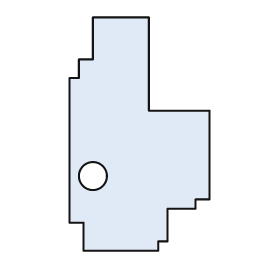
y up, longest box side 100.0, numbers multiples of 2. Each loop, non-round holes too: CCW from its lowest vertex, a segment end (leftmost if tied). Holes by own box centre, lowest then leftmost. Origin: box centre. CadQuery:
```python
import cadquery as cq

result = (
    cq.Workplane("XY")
    .moveTo(-24.0, -50.0)
    .lineTo(8.0, -50.0)
    .lineTo(8.0, -46.0)
    .lineTo(12.0, -46.0)
    .lineTo(12.0, -32.0)
    .lineTo(24.0, -32.0)
    .lineTo(24.0, -28.0)
    .lineTo(30.0, -28.0)
    .lineTo(30.0, 10.0)
    .lineTo(4.0, 10.0)
    .lineTo(4.0, 50.0)
    .lineTo(-20.0, 50.0)
    .lineTo(-20.0, 32.0)
    .lineTo(-26.0, 32.0)
    .lineTo(-26.0, 24.0)
    .lineTo(-30.0, 24.0)
    .lineTo(-30.0, -38.0)
    .lineTo(-24.0, -38.0)
    .close()
    .moveTo(-20.0, -18.0)
    .circle(6.0)
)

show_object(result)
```